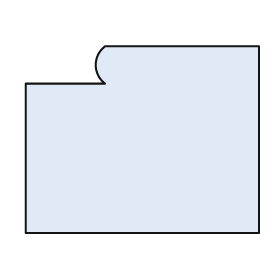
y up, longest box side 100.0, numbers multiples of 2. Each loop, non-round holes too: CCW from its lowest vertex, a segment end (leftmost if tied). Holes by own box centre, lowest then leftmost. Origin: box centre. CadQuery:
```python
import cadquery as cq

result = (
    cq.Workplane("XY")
    .moveTo(-50.0, -40.0)
    .lineTo(50.0, -40.0)
    .lineTo(50.0, 40.0)
    .lineTo(-16.0, 40.0)
    .threePointArc((-20.0, 32.0), (-16.0, 24.0))
    .lineTo(-50.0, 24.0)
    .close()
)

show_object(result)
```